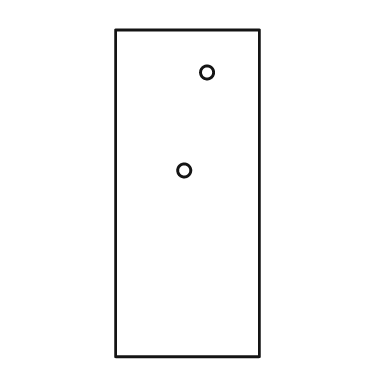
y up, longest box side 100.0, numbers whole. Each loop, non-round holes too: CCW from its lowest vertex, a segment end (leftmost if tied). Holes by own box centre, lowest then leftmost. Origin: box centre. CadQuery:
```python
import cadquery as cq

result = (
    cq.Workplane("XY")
    .moveTo(-22.0, -50.0)
    .lineTo(22.0, -50.0)
    .lineTo(22.0, 50.0)
    .lineTo(-22.0, 50.0)
    .close()
    .moveTo(-1.0, 7.0)
    .circle(2.0)
    .moveTo(6.0, 37.0)
    .circle(2.0)
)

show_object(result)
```